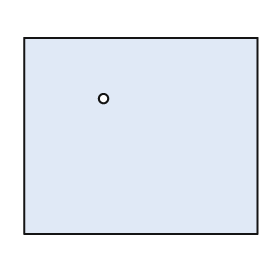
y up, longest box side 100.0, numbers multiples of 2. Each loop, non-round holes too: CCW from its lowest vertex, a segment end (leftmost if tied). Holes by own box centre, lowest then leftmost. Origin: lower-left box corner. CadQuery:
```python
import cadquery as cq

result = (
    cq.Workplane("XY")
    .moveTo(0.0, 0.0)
    .lineTo(100.0, 0.0)
    .lineTo(100.0, 84.0)
    .lineTo(0.0, 84.0)
    .close()
    .moveTo(34.0, 58.0)
    .circle(2.0)
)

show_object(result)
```